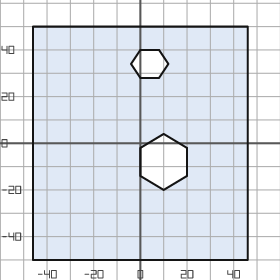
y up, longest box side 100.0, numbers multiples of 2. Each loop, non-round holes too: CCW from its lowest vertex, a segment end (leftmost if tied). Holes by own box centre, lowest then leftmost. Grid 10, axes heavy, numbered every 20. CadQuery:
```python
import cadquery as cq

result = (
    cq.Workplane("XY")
    .moveTo(-46.0, -50.0)
    .lineTo(46.0, -50.0)
    .lineTo(46.0, 50.0)
    .lineTo(-46.0, 50.0)
    .close()
    .moveTo(10.0, -20.0)
    .lineTo(20.0, -14.0)
    .lineTo(20.0, -2.0)
    .lineTo(10.0, 4.0)
    .lineTo(0.0, -2.0)
    .lineTo(0.0, -14.0)
    .close()
    .moveTo(0.0, 28.0)
    .lineTo(8.0, 28.0)
    .lineTo(12.0, 34.0)
    .lineTo(8.0, 40.0)
    .lineTo(0.0, 40.0)
    .lineTo(-4.0, 34.0)
    .close()
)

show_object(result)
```